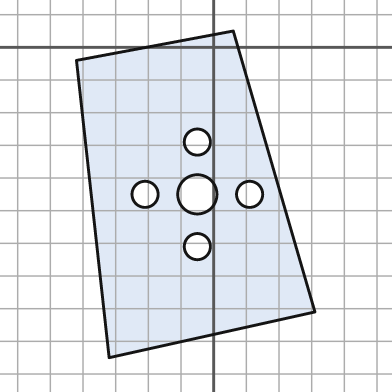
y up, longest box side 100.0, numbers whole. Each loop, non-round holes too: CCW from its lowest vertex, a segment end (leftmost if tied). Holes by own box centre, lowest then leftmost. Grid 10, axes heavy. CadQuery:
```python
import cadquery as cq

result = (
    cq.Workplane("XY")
    .moveTo(-32.0, -95.0)
    .lineTo(31.0, -81.0)
    .lineTo(6.0, 5.0)
    .lineTo(-42.0, -4.0)
    .close()
    .moveTo(-5.0, -61.0)
    .circle(4.0)
    .moveTo(-21.0, -45.0)
    .circle(4.0)
    .moveTo(-5.0, -45.0)
    .circle(6.0)
    .moveTo(11.0, -45.0)
    .circle(4.0)
    .moveTo(-5.0, -29.0)
    .circle(4.0)
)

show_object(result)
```